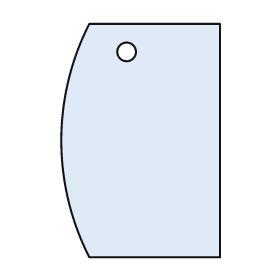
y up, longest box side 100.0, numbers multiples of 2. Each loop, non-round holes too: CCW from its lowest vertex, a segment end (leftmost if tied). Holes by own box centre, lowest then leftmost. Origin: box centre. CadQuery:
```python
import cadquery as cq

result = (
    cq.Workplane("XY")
    .moveTo(-22.0, -50.0)
    .lineTo(34.0, -50.0)
    .lineTo(34.0, 50.0)
    .lineTo(-22.0, 50.0)
    .threePointArc((-34.0, 0.0), (-22.0, -50.0))
    .close()
    .moveTo(-6.0, 38.0)
    .circle(4.0)
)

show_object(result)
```